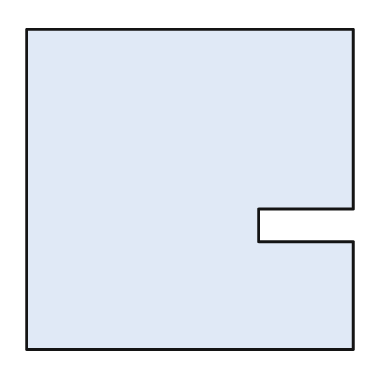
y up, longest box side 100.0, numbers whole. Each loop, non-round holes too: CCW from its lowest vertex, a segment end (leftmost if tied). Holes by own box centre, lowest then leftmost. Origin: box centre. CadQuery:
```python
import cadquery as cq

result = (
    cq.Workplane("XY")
    .moveTo(-50.0, -49.0)
    .lineTo(50.0, -49.0)
    .lineTo(50.0, -16.0)
    .lineTo(21.0, -16.0)
    .lineTo(21.0, -6.0)
    .lineTo(50.0, -6.0)
    .lineTo(50.0, 49.0)
    .lineTo(-50.0, 49.0)
    .close()
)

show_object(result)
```